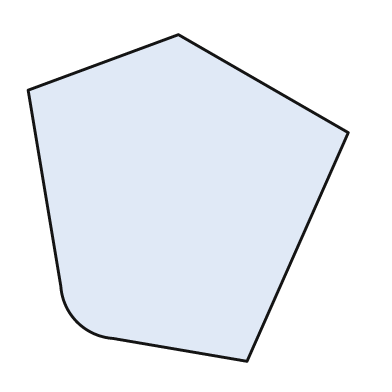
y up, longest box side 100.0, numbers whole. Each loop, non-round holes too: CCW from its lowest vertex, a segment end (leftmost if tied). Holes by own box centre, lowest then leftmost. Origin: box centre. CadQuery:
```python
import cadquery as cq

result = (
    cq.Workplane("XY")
    .moveTo(18.0, -50.0)
    .lineTo(49.0, 20.0)
    .lineTo(-3.0, 50.0)
    .lineTo(-49.0, 33.0)
    .lineTo(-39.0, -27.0)
    .threePointArc((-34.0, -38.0), (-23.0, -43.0))
    .close()
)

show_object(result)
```